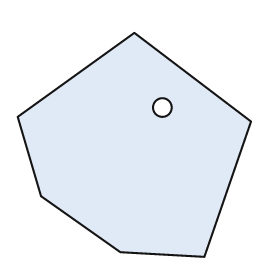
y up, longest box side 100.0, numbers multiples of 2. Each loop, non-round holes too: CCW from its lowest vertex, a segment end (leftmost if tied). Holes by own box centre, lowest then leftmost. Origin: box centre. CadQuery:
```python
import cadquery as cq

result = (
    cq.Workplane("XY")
    .moveTo(30.0, -48.0)
    .lineTo(50.0, 10.0)
    .lineTo(0.0, 48.0)
    .lineTo(-50.0, 12.0)
    .lineTo(-40.0, -22.0)
    .lineTo(-6.0, -46.0)
    .close()
    .moveTo(12.0, 16.0)
    .circle(4.0)
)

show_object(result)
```